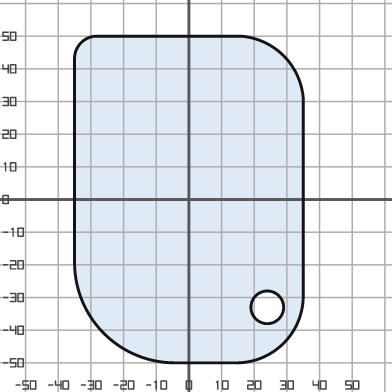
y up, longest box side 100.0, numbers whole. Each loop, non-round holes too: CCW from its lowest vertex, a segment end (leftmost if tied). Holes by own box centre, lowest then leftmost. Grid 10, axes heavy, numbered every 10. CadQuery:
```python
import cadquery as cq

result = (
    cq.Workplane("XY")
    .moveTo(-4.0, -50.0)
    .lineTo(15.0, -50.0)
    .threePointArc((29.0, -44.0), (35.0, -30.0))
    .lineTo(35.0, 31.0)
    .threePointArc((29.0, 44.0), (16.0, 50.0))
    .lineTo(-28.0, 50.0)
    .threePointArc((-33.0, 48.0), (-35.0, 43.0))
    .lineTo(-35.0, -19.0)
    .threePointArc((-26.0, -41.0), (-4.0, -50.0))
    .close()
    .moveTo(24.0, -33.0)
    .circle(5.0)
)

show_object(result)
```